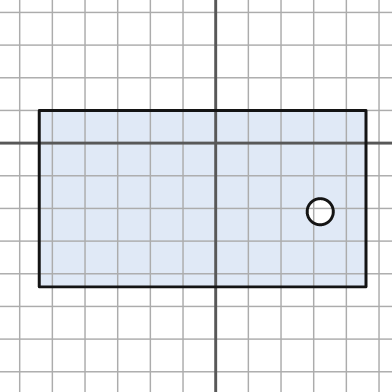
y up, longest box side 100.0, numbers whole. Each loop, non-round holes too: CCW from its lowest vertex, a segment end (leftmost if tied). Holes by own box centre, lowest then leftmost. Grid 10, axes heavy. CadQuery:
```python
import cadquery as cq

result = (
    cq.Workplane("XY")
    .moveTo(-54.0, -44.0)
    .lineTo(46.0, -44.0)
    .lineTo(46.0, 10.0)
    .lineTo(-54.0, 10.0)
    .close()
    .moveTo(32.0, -21.0)
    .circle(4.0)
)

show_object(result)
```